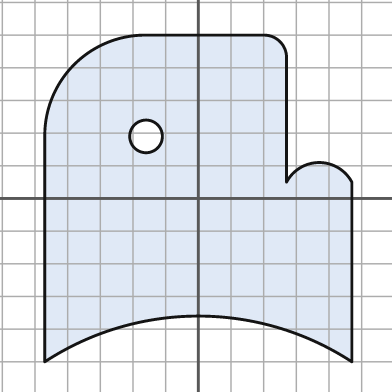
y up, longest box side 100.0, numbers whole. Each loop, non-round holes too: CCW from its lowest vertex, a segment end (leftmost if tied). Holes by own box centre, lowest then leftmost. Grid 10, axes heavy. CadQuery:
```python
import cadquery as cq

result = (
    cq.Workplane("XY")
    .moveTo(-47.0, -50.0)
    .threePointArc((0.0, -36.0), (47.0, -50.0))
    .lineTo(47.0, 5.0)
    .threePointArc((37.0, 11.0), (27.0, 5.0))
    .lineTo(27.0, 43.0)
    .threePointArc((25.0, 48.0), (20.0, 50.0))
    .lineTo(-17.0, 50.0)
    .threePointArc((-38.0, 41.0), (-47.0, 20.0))
    .close()
    .moveTo(-16.0, 19.0)
    .circle(5.0)
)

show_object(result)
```